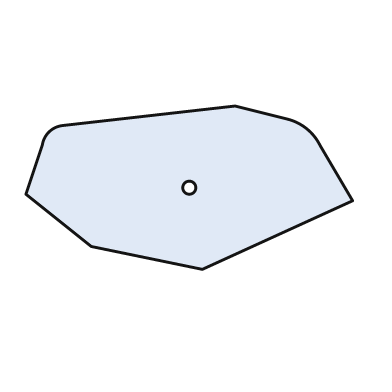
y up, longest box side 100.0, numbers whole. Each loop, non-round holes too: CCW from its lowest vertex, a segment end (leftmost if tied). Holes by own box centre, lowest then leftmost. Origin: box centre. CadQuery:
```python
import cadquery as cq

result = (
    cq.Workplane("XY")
    .moveTo(4.0, -25.0)
    .lineTo(50.0, -4.0)
    .lineTo(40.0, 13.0)
    .threePointArc((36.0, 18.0), (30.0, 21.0))
    .lineTo(14.0, 25.0)
    .lineTo(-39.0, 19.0)
    .threePointArc((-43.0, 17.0), (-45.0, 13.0))
    .lineTo(-50.0, -2.0)
    .lineTo(-30.0, -18.0)
    .close()
    .moveTo(0.0, 0.0)
    .circle(2.0)
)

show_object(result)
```